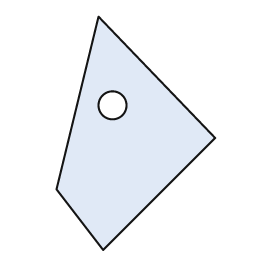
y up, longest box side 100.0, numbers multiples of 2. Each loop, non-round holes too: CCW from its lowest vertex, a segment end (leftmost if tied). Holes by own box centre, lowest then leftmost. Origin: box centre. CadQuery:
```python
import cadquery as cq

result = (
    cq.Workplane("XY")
    .moveTo(-14.0, -50.0)
    .lineTo(34.0, -2.0)
    .lineTo(-16.0, 50.0)
    .lineTo(-34.0, -24.0)
    .close()
    .moveTo(-10.0, 12.0)
    .circle(6.0)
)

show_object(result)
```